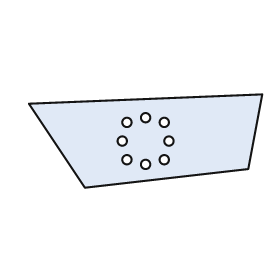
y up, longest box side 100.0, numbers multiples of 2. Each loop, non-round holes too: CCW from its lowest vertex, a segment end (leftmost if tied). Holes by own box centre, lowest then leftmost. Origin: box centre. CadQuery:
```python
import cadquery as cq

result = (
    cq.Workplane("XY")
    .moveTo(-26.0, -20.0)
    .lineTo(44.0, -12.0)
    .lineTo(50.0, 20.0)
    .lineTo(-50.0, 16.0)
    .close()
    .moveTo(0.0, -10.0)
    .circle(2.0)
    .moveTo(-8.0, -8.0)
    .circle(2.0)
    .moveTo(8.0, -8.0)
    .circle(2.0)
    .moveTo(-10.0, 0.0)
    .circle(2.0)
    .moveTo(10.0, 0.0)
    .circle(2.0)
    .moveTo(-8.0, 8.0)
    .circle(2.0)
    .moveTo(8.0, 8.0)
    .circle(2.0)
    .moveTo(0.0, 10.0)
    .circle(2.0)
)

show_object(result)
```